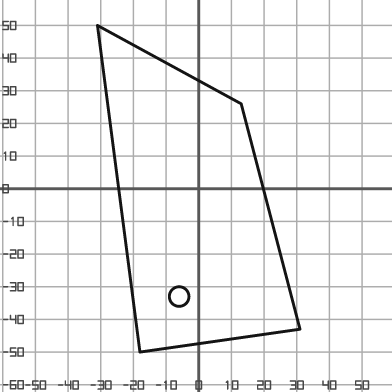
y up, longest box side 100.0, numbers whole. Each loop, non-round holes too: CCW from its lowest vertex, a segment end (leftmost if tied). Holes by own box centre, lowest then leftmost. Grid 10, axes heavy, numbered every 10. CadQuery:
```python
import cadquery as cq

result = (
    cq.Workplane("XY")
    .moveTo(-18.0, -50.0)
    .lineTo(31.0, -43.0)
    .lineTo(13.0, 26.0)
    .lineTo(-31.0, 50.0)
    .close()
    .moveTo(-6.0, -33.0)
    .circle(3.0)
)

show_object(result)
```